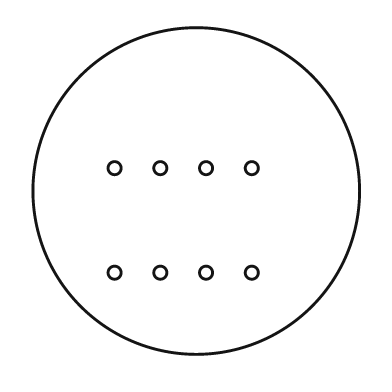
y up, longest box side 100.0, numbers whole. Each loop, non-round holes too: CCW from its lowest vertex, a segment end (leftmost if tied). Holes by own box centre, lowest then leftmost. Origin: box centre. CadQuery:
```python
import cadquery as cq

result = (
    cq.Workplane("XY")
    .moveTo(0.0, 0.0)
    .circle(50.0)
    .moveTo(-25.0, -25.0)
    .circle(2.0)
    .moveTo(-11.0, -25.0)
    .circle(2.0)
    .moveTo(3.0, -25.0)
    .circle(2.0)
    .moveTo(17.0, -25.0)
    .circle(2.0)
    .moveTo(-25.0, 7.0)
    .circle(2.0)
    .moveTo(-11.0, 7.0)
    .circle(2.0)
    .moveTo(3.0, 7.0)
    .circle(2.0)
    .moveTo(17.0, 7.0)
    .circle(2.0)
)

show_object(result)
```